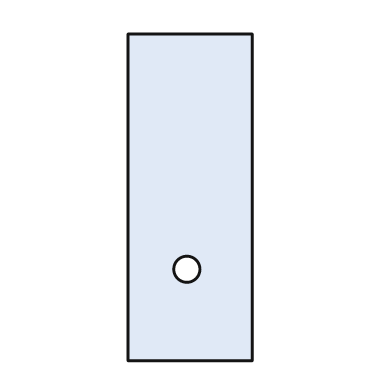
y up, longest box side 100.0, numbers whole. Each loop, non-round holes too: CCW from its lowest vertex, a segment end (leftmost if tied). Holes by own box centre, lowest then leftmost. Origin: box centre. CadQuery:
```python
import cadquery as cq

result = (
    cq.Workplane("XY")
    .moveTo(-19.0, -50.0)
    .lineTo(19.0, -50.0)
    .lineTo(19.0, 50.0)
    .lineTo(-19.0, 50.0)
    .close()
    .moveTo(-1.0, -22.0)
    .circle(4.0)
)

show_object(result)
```